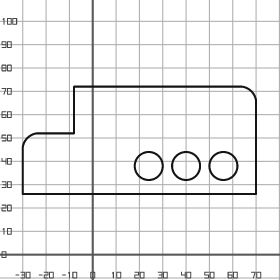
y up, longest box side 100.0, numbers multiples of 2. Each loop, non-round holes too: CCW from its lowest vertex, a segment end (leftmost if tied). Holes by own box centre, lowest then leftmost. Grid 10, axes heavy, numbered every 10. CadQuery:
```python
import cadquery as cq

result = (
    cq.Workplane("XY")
    .moveTo(-30.0, 26.0)
    .lineTo(70.0, 26.0)
    .lineTo(70.0, 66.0)
    .threePointArc((68.0, 70.0), (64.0, 72.0))
    .lineTo(-8.0, 72.0)
    .lineTo(-8.0, 52.0)
    .lineTo(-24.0, 52.0)
    .threePointArc((-28.0, 50.0), (-30.0, 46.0))
    .close()
    .moveTo(24.0, 38.0)
    .circle(6.0)
    .moveTo(40.0, 38.0)
    .circle(6.0)
    .moveTo(56.0, 38.0)
    .circle(6.0)
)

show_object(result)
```